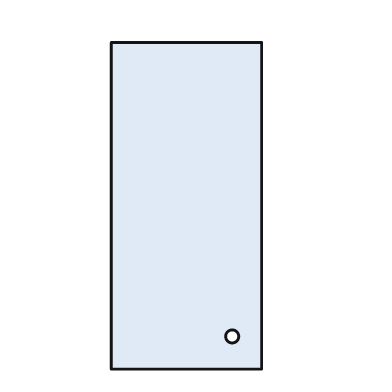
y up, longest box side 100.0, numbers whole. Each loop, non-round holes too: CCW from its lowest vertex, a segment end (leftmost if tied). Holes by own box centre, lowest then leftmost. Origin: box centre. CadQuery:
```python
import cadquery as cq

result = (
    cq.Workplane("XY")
    .moveTo(-23.0, -50.0)
    .lineTo(23.0, -50.0)
    .lineTo(23.0, 50.0)
    .lineTo(-23.0, 50.0)
    .close()
    .moveTo(14.0, -40.0)
    .circle(2.0)
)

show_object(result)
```